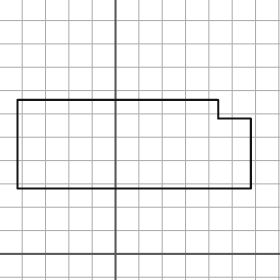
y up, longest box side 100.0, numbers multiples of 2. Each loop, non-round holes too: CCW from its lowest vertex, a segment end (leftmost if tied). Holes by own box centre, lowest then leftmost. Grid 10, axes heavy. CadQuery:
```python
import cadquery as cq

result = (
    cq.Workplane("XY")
    .moveTo(-42.0, 28.0)
    .lineTo(58.0, 28.0)
    .lineTo(58.0, 58.0)
    .lineTo(44.0, 58.0)
    .lineTo(44.0, 66.0)
    .lineTo(-42.0, 66.0)
    .close()
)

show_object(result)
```